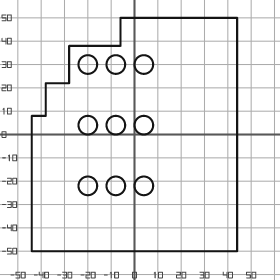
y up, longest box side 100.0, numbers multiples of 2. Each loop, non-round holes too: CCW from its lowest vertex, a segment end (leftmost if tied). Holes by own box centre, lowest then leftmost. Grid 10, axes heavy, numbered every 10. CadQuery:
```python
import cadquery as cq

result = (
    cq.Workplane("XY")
    .moveTo(-44.0, -50.0)
    .lineTo(44.0, -50.0)
    .lineTo(44.0, 50.0)
    .lineTo(-6.0, 50.0)
    .lineTo(-6.0, 38.0)
    .lineTo(-28.0, 38.0)
    .lineTo(-28.0, 22.0)
    .lineTo(-38.0, 22.0)
    .lineTo(-38.0, 8.0)
    .lineTo(-44.0, 8.0)
    .close()
    .moveTo(-20.0, -22.0)
    .circle(4.0)
    .moveTo(-8.0, -22.0)
    .circle(4.0)
    .moveTo(4.0, -22.0)
    .circle(4.0)
    .moveTo(-20.0, 4.0)
    .circle(4.0)
    .moveTo(-8.0, 4.0)
    .circle(4.0)
    .moveTo(4.0, 4.0)
    .circle(4.0)
    .moveTo(-20.0, 30.0)
    .circle(4.0)
    .moveTo(-8.0, 30.0)
    .circle(4.0)
    .moveTo(4.0, 30.0)
    .circle(4.0)
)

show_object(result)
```